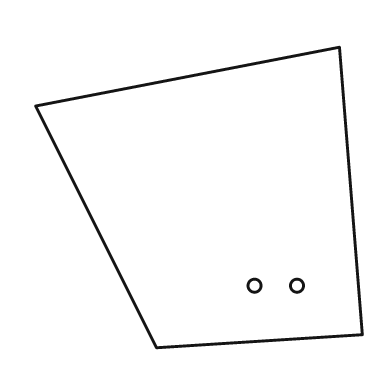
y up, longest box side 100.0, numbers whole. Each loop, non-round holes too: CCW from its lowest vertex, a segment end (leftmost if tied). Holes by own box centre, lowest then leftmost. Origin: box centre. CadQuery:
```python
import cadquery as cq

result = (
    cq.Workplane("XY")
    .moveTo(-13.0, -46.0)
    .lineTo(50.0, -42.0)
    .lineTo(43.0, 46.0)
    .lineTo(-50.0, 28.0)
    .close()
    .moveTo(17.0, -27.0)
    .circle(2.0)
    .moveTo(30.0, -27.0)
    .circle(2.0)
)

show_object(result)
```